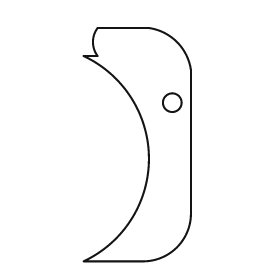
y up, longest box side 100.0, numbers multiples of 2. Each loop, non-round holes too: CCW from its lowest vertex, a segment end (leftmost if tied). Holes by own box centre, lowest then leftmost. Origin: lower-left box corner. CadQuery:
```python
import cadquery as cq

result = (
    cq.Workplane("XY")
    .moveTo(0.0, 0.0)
    .lineTo(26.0, 0.0)
    .threePointArc((40.0, 6.0), (46.0, 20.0))
    .lineTo(46.0, 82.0)
    .threePointArc((40.0, 94.0), (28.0, 100.0))
    .lineTo(6.0, 100.0)
    .threePointArc((4.0, 94.0), (6.0, 88.0))
    .lineTo(0.0, 88.0)
    .threePointArc((28.0, 44.0), (0.0, 0.0))
    .close()
    .moveTo(38.0, 68.0)
    .circle(4.0)
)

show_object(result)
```